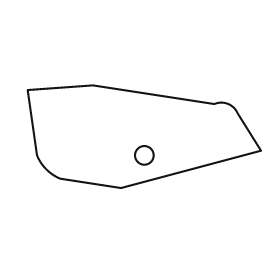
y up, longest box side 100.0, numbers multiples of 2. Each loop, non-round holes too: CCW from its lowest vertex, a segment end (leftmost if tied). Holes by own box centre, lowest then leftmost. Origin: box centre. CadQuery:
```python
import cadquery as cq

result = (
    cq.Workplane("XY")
    .moveTo(-10.0, -22.0)
    .lineTo(50.0, -6.0)
    .lineTo(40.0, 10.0)
    .threePointArc((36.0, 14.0), (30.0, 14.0))
    .lineTo(-22.0, 22.0)
    .lineTo(-50.0, 20.0)
    .lineTo(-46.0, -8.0)
    .threePointArc((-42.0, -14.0), (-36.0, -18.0))
    .close()
    .moveTo(0.0, -8.0)
    .circle(4.0)
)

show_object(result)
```